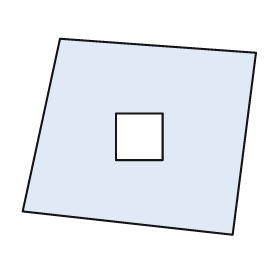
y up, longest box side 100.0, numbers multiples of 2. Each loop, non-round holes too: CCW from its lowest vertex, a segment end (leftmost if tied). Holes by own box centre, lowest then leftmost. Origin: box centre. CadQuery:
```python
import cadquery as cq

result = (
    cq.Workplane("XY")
    .moveTo(40.0, -42.0)
    .lineTo(50.0, 36.0)
    .lineTo(-34.0, 42.0)
    .lineTo(-50.0, -32.0)
    .close()
    .moveTo(-10.0, -10.0)
    .lineTo(10.0, -10.0)
    .lineTo(10.0, 10.0)
    .lineTo(-10.0, 10.0)
    .close()
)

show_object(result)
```